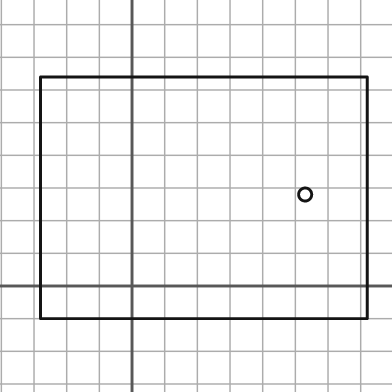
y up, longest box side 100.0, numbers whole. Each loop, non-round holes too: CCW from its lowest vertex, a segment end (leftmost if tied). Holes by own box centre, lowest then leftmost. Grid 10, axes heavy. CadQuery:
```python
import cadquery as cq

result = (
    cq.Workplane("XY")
    .moveTo(-28.0, -10.0)
    .lineTo(72.0, -10.0)
    .lineTo(72.0, 64.0)
    .lineTo(-28.0, 64.0)
    .close()
    .moveTo(53.0, 28.0)
    .circle(2.0)
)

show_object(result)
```